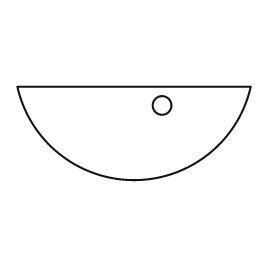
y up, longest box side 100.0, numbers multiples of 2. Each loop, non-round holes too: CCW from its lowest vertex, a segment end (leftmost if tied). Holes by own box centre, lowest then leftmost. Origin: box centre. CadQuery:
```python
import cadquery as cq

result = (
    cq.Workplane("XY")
    .moveTo(-50.0, 20.0)
    .threePointArc((0.0, -20.0), (50.0, 20.0))
    .close()
    .moveTo(12.0, 12.0)
    .circle(4.0)
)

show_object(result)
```